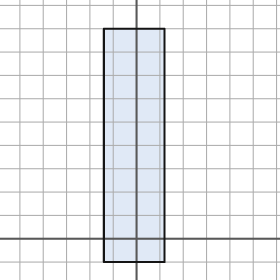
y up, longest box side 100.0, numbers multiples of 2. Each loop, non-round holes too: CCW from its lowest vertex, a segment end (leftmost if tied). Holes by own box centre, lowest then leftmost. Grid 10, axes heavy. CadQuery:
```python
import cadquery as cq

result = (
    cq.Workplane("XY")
    .moveTo(-14.0, -10.0)
    .lineTo(12.0, -10.0)
    .lineTo(12.0, 90.0)
    .lineTo(-14.0, 90.0)
    .close()
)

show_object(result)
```